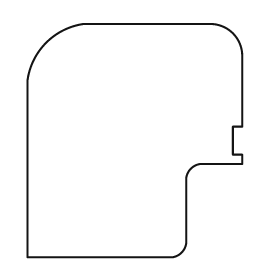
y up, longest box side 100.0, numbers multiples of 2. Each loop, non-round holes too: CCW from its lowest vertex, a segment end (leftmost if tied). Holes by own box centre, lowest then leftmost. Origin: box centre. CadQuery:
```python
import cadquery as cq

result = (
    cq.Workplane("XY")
    .moveTo(-46.0, -50.0)
    .lineTo(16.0, -50.0)
    .threePointArc((20.0, -48.0), (22.0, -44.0))
    .lineTo(22.0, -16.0)
    .threePointArc((24.0, -12.0), (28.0, -10.0))
    .lineTo(46.0, -10.0)
    .lineTo(46.0, -6.0)
    .lineTo(42.0, -6.0)
    .lineTo(42.0, 6.0)
    .lineTo(46.0, 6.0)
    .lineTo(46.0, 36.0)
    .threePointArc((42.0, 46.0), (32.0, 50.0))
    .lineTo(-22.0, 50.0)
    .threePointArc((-38.0, 42.0), (-46.0, 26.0))
    .close()
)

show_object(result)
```